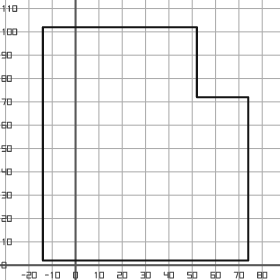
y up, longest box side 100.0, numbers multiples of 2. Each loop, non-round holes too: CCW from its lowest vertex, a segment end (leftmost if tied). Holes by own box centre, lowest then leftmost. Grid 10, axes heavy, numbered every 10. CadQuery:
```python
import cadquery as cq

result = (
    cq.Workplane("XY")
    .moveTo(-14.0, 2.0)
    .lineTo(74.0, 2.0)
    .lineTo(74.0, 72.0)
    .lineTo(52.0, 72.0)
    .lineTo(52.0, 102.0)
    .lineTo(-14.0, 102.0)
    .close()
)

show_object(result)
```